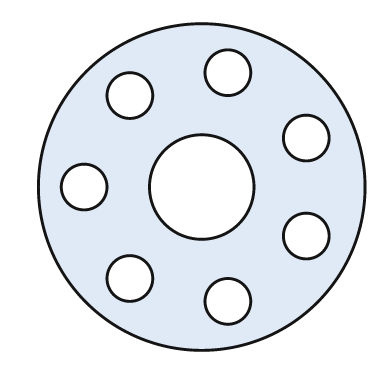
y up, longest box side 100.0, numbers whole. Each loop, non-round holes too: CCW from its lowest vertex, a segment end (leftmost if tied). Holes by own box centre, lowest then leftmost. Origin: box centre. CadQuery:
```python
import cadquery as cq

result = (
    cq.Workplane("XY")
    .moveTo(0.0, 0.0)
    .circle(50.0)
    .moveTo(8.0, -35.0)
    .circle(7.0)
    .moveTo(-22.0, -28.0)
    .circle(7.0)
    .moveTo(32.0, -15.0)
    .circle(7.0)
    .moveTo(-36.0, 0.0)
    .circle(7.0)
    .moveTo(0.0, 0.0)
    .circle(16.0)
    .moveTo(32.0, 15.0)
    .circle(7.0)
    .moveTo(-22.0, 28.0)
    .circle(7.0)
    .moveTo(8.0, 35.0)
    .circle(7.0)
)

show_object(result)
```